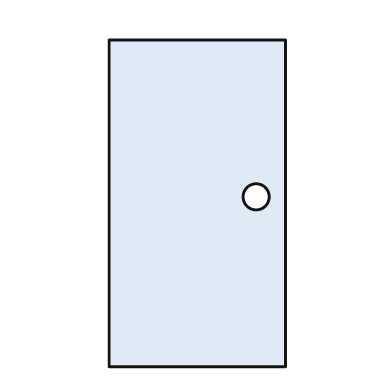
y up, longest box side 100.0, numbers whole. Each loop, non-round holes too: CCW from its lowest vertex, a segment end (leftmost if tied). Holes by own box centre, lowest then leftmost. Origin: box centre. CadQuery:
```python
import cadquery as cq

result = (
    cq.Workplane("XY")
    .moveTo(-27.0, -50.0)
    .lineTo(27.0, -50.0)
    .lineTo(27.0, 50.0)
    .lineTo(-27.0, 50.0)
    .close()
    .moveTo(18.0, 2.0)
    .circle(4.0)
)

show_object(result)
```